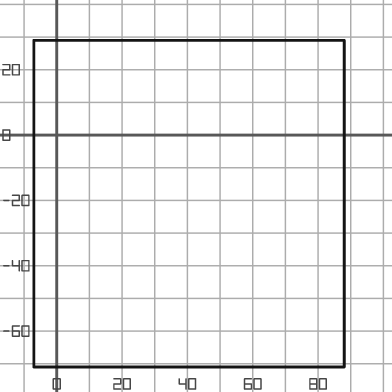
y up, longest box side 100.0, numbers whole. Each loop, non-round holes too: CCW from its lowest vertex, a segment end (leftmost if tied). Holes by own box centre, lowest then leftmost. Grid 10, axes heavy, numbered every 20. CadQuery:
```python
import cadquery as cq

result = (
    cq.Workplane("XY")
    .moveTo(-7.0, -71.0)
    .lineTo(88.0, -71.0)
    .lineTo(88.0, 29.0)
    .lineTo(-7.0, 29.0)
    .close()
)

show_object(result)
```